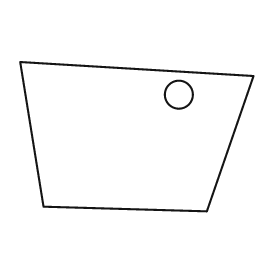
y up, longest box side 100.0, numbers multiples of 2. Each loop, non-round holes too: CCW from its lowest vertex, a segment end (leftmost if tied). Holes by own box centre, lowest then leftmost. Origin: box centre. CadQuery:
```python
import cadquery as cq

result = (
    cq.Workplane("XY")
    .moveTo(30.0, -32.0)
    .lineTo(50.0, 26.0)
    .lineTo(-50.0, 32.0)
    .lineTo(-40.0, -30.0)
    .close()
    .moveTo(18.0, 18.0)
    .circle(6.0)
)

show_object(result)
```